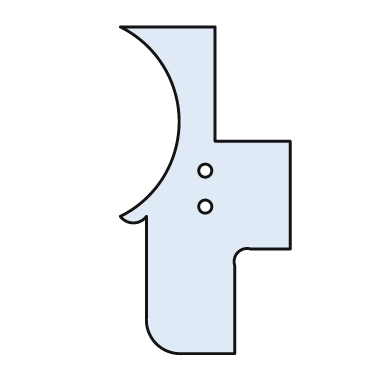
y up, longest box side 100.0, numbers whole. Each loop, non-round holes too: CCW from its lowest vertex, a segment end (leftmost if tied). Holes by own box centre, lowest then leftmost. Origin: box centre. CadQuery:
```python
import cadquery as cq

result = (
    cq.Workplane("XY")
    .moveTo(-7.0, -50.0)
    .lineTo(9.0, -50.0)
    .lineTo(9.0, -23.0)
    .threePointArc((10.0, -19.0), (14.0, -18.0))
    .lineTo(26.0, -18.0)
    .lineTo(26.0, 15.0)
    .lineTo(3.0, 15.0)
    .lineTo(3.0, 50.0)
    .lineTo(-26.0, 50.0)
    .threePointArc((-8.0, 21.0), (-26.0, -8.0))
    .threePointArc((-22.0, -10.0), (-18.0, -8.0))
    .lineTo(-18.0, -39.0)
    .threePointArc((-15.0, -47.0), (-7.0, -50.0))
    .close()
    .moveTo(0.0, -5.0)
    .circle(2.0)
    .moveTo(0.0, 6.0)
    .circle(2.0)
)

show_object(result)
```